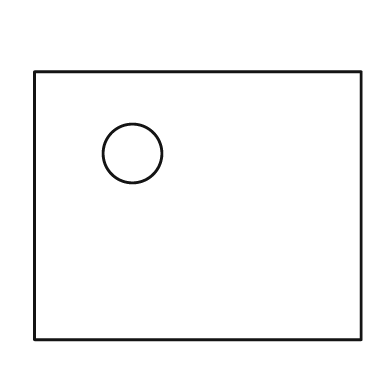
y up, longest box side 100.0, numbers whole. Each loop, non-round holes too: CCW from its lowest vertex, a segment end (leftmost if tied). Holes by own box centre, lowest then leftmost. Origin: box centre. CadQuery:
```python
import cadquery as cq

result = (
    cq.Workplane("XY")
    .moveTo(-50.0, -41.0)
    .lineTo(50.0, -41.0)
    .lineTo(50.0, 41.0)
    .lineTo(-50.0, 41.0)
    .close()
    .moveTo(-20.0, 16.0)
    .circle(9.0)
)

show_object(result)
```